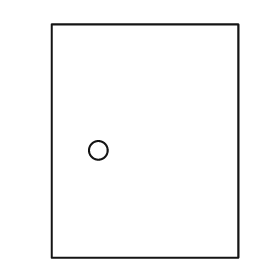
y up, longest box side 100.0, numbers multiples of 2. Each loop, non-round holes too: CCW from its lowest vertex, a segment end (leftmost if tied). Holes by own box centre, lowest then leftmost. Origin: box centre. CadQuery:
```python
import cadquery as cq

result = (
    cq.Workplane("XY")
    .moveTo(-40.0, -50.0)
    .lineTo(40.0, -50.0)
    .lineTo(40.0, 50.0)
    .lineTo(-40.0, 50.0)
    .close()
    .moveTo(-20.0, -4.0)
    .circle(4.0)
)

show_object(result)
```